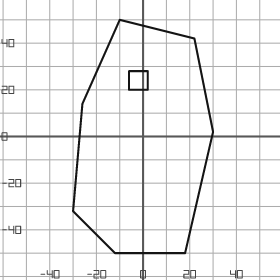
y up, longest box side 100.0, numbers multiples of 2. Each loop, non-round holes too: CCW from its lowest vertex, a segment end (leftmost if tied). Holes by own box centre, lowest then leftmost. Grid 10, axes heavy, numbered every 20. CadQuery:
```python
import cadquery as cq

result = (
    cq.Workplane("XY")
    .moveTo(-12.0, -50.0)
    .lineTo(18.0, -50.0)
    .lineTo(30.0, 2.0)
    .lineTo(22.0, 42.0)
    .lineTo(-10.0, 50.0)
    .lineTo(-26.0, 14.0)
    .lineTo(-30.0, -32.0)
    .close()
    .moveTo(-6.0, 20.0)
    .lineTo(2.0, 20.0)
    .lineTo(2.0, 28.0)
    .lineTo(-6.0, 28.0)
    .close()
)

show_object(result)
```